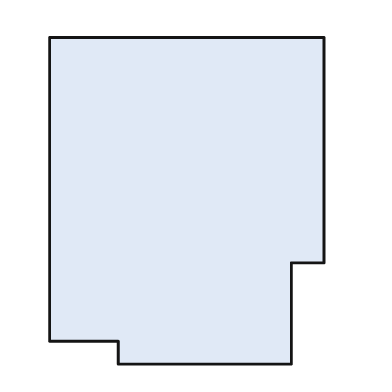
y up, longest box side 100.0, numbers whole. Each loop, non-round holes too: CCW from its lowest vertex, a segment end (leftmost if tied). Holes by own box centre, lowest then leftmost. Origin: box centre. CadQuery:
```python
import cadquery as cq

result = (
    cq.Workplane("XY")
    .moveTo(-21.0, -50.0)
    .lineTo(32.0, -50.0)
    .lineTo(32.0, -19.0)
    .lineTo(42.0, -19.0)
    .lineTo(42.0, 50.0)
    .lineTo(-42.0, 50.0)
    .lineTo(-42.0, -43.0)
    .lineTo(-21.0, -43.0)
    .close()
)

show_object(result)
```